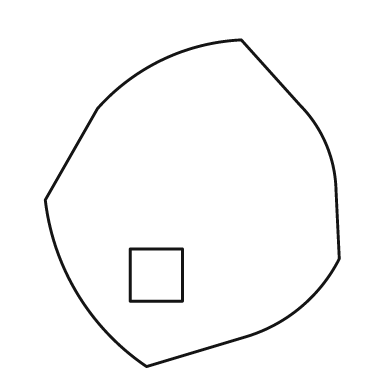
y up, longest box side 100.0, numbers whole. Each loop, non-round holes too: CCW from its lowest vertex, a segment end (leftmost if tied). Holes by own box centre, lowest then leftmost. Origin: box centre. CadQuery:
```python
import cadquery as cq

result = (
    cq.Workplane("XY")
    .moveTo(-14.0, -50.0)
    .lineTo(16.0, -41.0)
    .threePointArc((33.0, -32.0), (45.0, -17.0))
    .lineTo(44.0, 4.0)
    .threePointArc((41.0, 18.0), (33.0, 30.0))
    .lineTo(15.0, 50.0)
    .threePointArc((-9.0, 44.0), (-29.0, 29.0))
    .lineTo(-45.0, 1.0)
    .threePointArc((-35.0, -28.0), (-14.0, -50.0))
    .close()
    .moveTo(-19.0, -30.0)
    .lineTo(-3.0, -30.0)
    .lineTo(-3.0, -14.0)
    .lineTo(-19.0, -14.0)
    .close()
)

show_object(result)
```